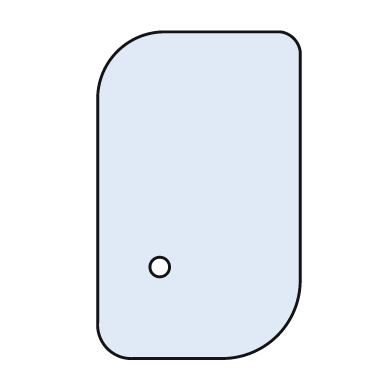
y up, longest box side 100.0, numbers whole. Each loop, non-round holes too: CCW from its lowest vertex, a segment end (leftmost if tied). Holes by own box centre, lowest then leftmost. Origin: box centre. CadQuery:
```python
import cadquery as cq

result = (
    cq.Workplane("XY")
    .moveTo(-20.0, -50.0)
    .lineTo(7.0, -50.0)
    .threePointArc((24.0, -43.0), (31.0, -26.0))
    .lineTo(31.0, 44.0)
    .threePointArc((29.0, 48.0), (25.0, 50.0))
    .lineTo(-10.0, 50.0)
    .threePointArc((-25.0, 44.0), (-31.0, 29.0))
    .lineTo(-31.0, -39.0)
    .threePointArc((-28.0, -47.0), (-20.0, -50.0))
    .close()
    .moveTo(-12.0, -22.0)
    .circle(3.0)
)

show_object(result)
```